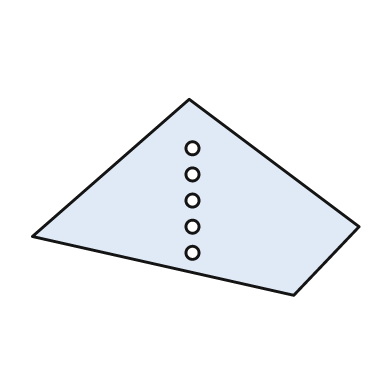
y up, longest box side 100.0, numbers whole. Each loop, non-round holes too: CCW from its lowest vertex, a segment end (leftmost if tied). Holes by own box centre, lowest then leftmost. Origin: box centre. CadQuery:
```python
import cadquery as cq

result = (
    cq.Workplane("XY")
    .moveTo(30.0, -30.0)
    .lineTo(50.0, -9.0)
    .lineTo(-2.0, 30.0)
    .lineTo(-50.0, -12.0)
    .close()
    .moveTo(-1.0, -17.0)
    .circle(2.0)
    .moveTo(-1.0, -9.0)
    .circle(2.0)
    .moveTo(-1.0, -1.0)
    .circle(2.0)
    .moveTo(-1.0, 7.0)
    .circle(2.0)
    .moveTo(-1.0, 15.0)
    .circle(2.0)
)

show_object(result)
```